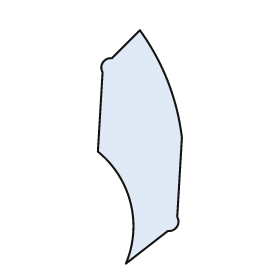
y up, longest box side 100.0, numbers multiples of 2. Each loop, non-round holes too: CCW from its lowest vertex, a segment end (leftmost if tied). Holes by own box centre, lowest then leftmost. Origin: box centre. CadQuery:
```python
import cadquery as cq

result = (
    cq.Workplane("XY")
    .moveTo(-6.0, -50.0)
    .lineTo(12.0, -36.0)
    .threePointArc((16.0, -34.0), (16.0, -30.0))
    .lineTo(18.0, 4.0)
    .threePointArc((12.0, 28.0), (0.0, 50.0))
    .lineTo(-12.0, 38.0)
    .threePointArc((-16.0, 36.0), (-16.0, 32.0))
    .lineTo(-18.0, -2.0)
    .threePointArc((-4.0, -24.0), (-6.0, -50.0))
    .close()
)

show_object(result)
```